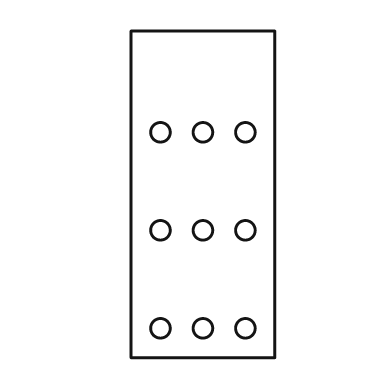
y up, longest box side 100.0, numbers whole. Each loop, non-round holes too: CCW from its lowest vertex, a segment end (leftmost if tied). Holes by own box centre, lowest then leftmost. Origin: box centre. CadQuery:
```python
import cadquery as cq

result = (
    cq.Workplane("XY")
    .moveTo(-22.0, -50.0)
    .lineTo(22.0, -50.0)
    .lineTo(22.0, 50.0)
    .lineTo(-22.0, 50.0)
    .close()
    .moveTo(-13.0, -41.0)
    .circle(3.0)
    .moveTo(0.0, -41.0)
    .circle(3.0)
    .moveTo(13.0, -41.0)
    .circle(3.0)
    .moveTo(-13.0, -11.0)
    .circle(3.0)
    .moveTo(0.0, -11.0)
    .circle(3.0)
    .moveTo(13.0, -11.0)
    .circle(3.0)
    .moveTo(-13.0, 19.0)
    .circle(3.0)
    .moveTo(0.0, 19.0)
    .circle(3.0)
    .moveTo(13.0, 19.0)
    .circle(3.0)
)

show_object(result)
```